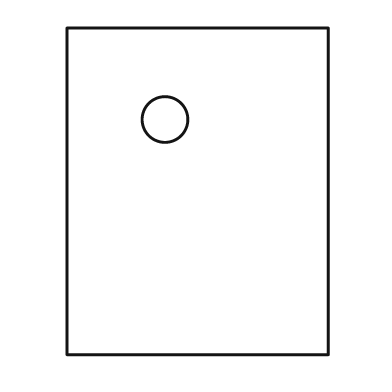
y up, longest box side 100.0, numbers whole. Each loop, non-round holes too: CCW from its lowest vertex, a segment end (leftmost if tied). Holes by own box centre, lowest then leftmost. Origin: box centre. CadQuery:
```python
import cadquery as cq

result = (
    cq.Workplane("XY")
    .moveTo(-40.0, -50.0)
    .lineTo(40.0, -50.0)
    .lineTo(40.0, 50.0)
    .lineTo(-40.0, 50.0)
    .close()
    .moveTo(-10.0, 22.0)
    .circle(7.0)
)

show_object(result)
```